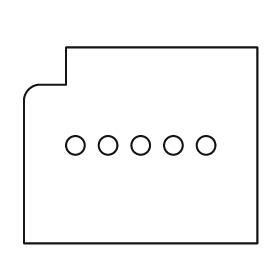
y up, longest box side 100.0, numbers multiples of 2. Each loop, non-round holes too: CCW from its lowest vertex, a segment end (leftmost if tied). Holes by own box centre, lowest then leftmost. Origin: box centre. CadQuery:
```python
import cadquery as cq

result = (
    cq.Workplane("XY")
    .moveTo(-50.0, -42.0)
    .lineTo(50.0, -42.0)
    .lineTo(50.0, 42.0)
    .lineTo(-32.0, 42.0)
    .lineTo(-32.0, 26.0)
    .lineTo(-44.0, 26.0)
    .threePointArc((-48.0, 24.0), (-50.0, 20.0))
    .close()
    .moveTo(-28.0, 0.0)
    .circle(4.0)
    .moveTo(-14.0, 0.0)
    .circle(4.0)
    .moveTo(0.0, 0.0)
    .circle(4.0)
    .moveTo(14.0, 0.0)
    .circle(4.0)
    .moveTo(28.0, 0.0)
    .circle(4.0)
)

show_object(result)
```